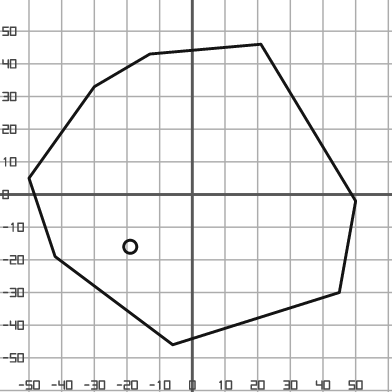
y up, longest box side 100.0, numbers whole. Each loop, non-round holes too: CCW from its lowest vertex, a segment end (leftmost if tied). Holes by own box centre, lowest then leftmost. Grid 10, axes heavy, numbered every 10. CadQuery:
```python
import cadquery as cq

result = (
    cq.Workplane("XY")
    .moveTo(-6.0, -46.0)
    .lineTo(45.0, -30.0)
    .lineTo(50.0, -2.0)
    .lineTo(21.0, 46.0)
    .lineTo(-13.0, 43.0)
    .lineTo(-30.0, 33.0)
    .lineTo(-50.0, 5.0)
    .lineTo(-42.0, -19.0)
    .close()
    .moveTo(-19.0, -16.0)
    .circle(2.0)
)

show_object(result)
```